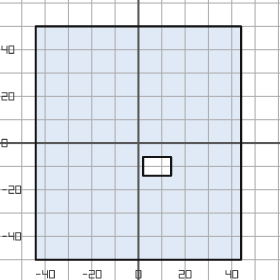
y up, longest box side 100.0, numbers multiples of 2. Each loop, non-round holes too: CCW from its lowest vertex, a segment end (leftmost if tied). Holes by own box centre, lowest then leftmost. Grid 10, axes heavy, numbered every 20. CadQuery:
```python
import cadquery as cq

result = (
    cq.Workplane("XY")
    .moveTo(-44.0, -50.0)
    .lineTo(44.0, -50.0)
    .lineTo(44.0, 50.0)
    .lineTo(-44.0, 50.0)
    .close()
    .moveTo(2.0, -14.0)
    .lineTo(14.0, -14.0)
    .lineTo(14.0, -6.0)
    .lineTo(2.0, -6.0)
    .close()
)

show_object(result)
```